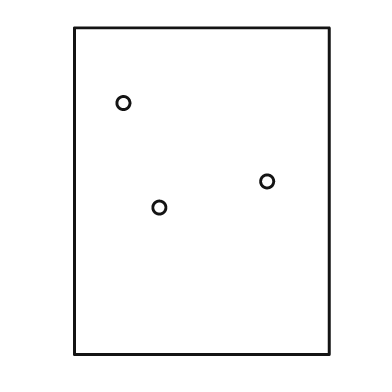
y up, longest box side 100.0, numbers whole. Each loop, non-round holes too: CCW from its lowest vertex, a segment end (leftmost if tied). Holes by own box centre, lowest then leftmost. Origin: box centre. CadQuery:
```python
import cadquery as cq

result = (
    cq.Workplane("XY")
    .moveTo(-39.0, -50.0)
    .lineTo(39.0, -50.0)
    .lineTo(39.0, 50.0)
    .lineTo(-39.0, 50.0)
    .close()
    .moveTo(-13.0, -5.0)
    .circle(2.0)
    .moveTo(20.0, 3.0)
    .circle(2.0)
    .moveTo(-24.0, 27.0)
    .circle(2.0)
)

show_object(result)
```